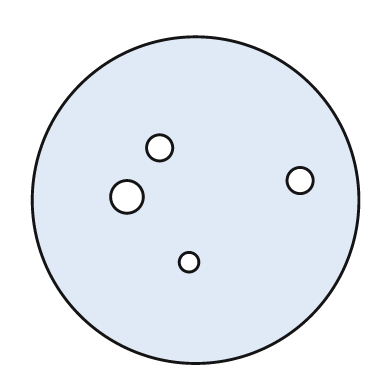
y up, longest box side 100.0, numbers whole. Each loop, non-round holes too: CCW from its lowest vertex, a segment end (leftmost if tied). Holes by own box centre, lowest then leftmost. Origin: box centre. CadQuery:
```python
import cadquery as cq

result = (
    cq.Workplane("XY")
    .moveTo(0.0, 0.0)
    .circle(50.0)
    .moveTo(-2.0, -19.0)
    .circle(3.0)
    .moveTo(-21.0, 1.0)
    .circle(5.0)
    .moveTo(32.0, 6.0)
    .circle(4.0)
    .moveTo(-11.0, 16.0)
    .circle(4.0)
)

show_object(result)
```